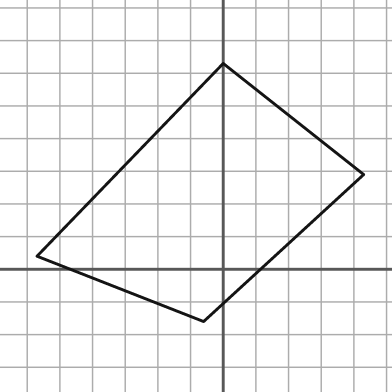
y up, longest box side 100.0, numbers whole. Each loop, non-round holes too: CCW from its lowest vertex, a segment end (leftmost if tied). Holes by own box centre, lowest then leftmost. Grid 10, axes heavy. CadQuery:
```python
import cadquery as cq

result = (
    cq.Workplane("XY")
    .moveTo(-6.0, -16.0)
    .lineTo(43.0, 29.0)
    .lineTo(0.0, 63.0)
    .lineTo(-57.0, 4.0)
    .close()
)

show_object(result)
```